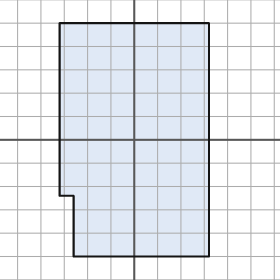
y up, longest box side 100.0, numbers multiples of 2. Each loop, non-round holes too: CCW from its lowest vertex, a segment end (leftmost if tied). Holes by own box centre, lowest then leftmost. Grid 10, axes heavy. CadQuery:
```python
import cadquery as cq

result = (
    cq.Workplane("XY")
    .moveTo(-26.0, -50.0)
    .lineTo(32.0, -50.0)
    .lineTo(32.0, 50.0)
    .lineTo(-32.0, 50.0)
    .lineTo(-32.0, -24.0)
    .lineTo(-26.0, -24.0)
    .close()
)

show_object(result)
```